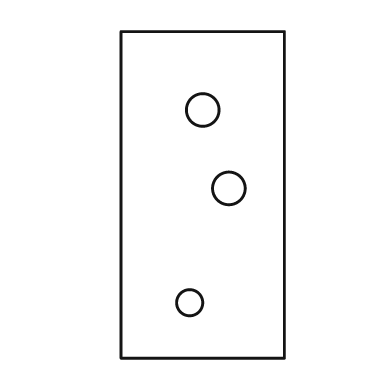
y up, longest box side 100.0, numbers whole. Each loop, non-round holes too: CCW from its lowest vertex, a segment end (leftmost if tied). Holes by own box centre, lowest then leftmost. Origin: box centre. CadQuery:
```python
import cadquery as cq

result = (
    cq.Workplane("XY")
    .moveTo(-25.0, -50.0)
    .lineTo(25.0, -50.0)
    .lineTo(25.0, 50.0)
    .lineTo(-25.0, 50.0)
    .close()
    .moveTo(-4.0, -33.0)
    .circle(4.0)
    .moveTo(8.0, 2.0)
    .circle(5.0)
    .moveTo(0.0, 26.0)
    .circle(5.0)
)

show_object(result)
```